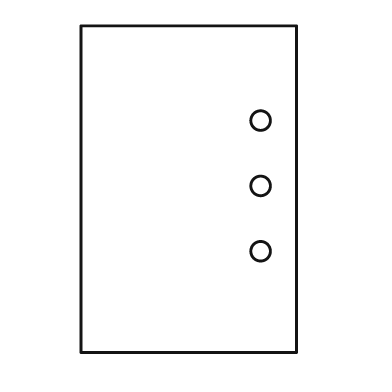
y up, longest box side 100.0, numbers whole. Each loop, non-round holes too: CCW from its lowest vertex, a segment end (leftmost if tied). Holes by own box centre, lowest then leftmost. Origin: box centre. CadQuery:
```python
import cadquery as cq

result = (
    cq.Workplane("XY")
    .moveTo(-33.0, -50.0)
    .lineTo(33.0, -50.0)
    .lineTo(33.0, 50.0)
    .lineTo(-33.0, 50.0)
    .close()
    .moveTo(22.0, -19.0)
    .circle(3.0)
    .moveTo(22.0, 1.0)
    .circle(3.0)
    .moveTo(22.0, 21.0)
    .circle(3.0)
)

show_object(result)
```